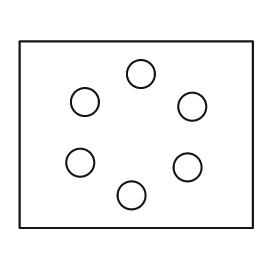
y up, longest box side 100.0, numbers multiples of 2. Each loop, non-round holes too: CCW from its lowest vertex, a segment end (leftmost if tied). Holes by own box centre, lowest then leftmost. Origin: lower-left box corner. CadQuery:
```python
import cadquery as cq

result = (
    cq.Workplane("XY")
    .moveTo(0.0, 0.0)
    .lineTo(100.0, 0.0)
    .lineTo(100.0, 80.0)
    .lineTo(0.0, 80.0)
    .close()
    .moveTo(48.0, 14.0)
    .circle(6.0)
    .moveTo(72.0, 26.0)
    .circle(6.0)
    .moveTo(26.0, 28.0)
    .circle(6.0)
    .moveTo(74.0, 52.0)
    .circle(6.0)
    .moveTo(28.0, 54.0)
    .circle(6.0)
    .moveTo(52.0, 66.0)
    .circle(6.0)
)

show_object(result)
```